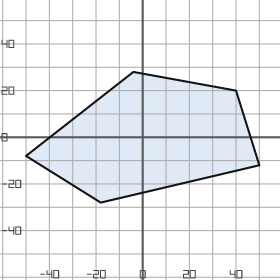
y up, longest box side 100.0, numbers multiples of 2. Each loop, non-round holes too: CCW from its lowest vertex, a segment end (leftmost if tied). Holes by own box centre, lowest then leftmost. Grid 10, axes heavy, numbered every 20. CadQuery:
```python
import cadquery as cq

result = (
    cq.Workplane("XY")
    .moveTo(-18.0, -28.0)
    .lineTo(50.0, -12.0)
    .lineTo(40.0, 20.0)
    .lineTo(-4.0, 28.0)
    .lineTo(-50.0, -8.0)
    .close()
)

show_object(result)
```